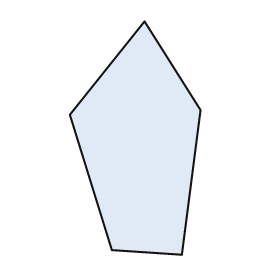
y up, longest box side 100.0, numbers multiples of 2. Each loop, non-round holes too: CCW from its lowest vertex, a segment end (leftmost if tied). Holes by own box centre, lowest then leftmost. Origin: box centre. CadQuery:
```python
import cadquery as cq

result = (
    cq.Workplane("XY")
    .moveTo(20.0, -50.0)
    .lineTo(28.0, 12.0)
    .lineTo(4.0, 50.0)
    .lineTo(-28.0, 10.0)
    .lineTo(-10.0, -48.0)
    .close()
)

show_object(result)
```